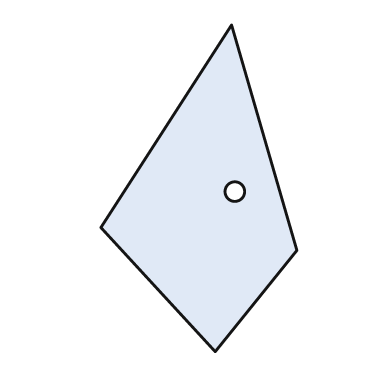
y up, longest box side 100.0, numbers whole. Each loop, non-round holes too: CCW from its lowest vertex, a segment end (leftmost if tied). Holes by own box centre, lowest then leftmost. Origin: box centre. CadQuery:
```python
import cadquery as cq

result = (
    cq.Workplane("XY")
    .moveTo(5.0, -50.0)
    .lineTo(30.0, -19.0)
    .lineTo(10.0, 50.0)
    .lineTo(-30.0, -12.0)
    .close()
    .moveTo(11.0, -1.0)
    .circle(3.0)
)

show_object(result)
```